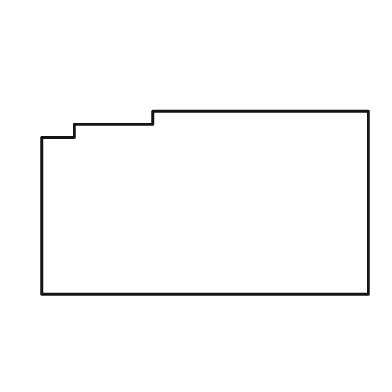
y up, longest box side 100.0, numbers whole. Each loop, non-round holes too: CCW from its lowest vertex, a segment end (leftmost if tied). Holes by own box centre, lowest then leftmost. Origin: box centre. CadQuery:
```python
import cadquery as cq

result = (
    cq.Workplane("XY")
    .moveTo(-50.0, -28.0)
    .lineTo(50.0, -28.0)
    .lineTo(50.0, 28.0)
    .lineTo(-16.0, 28.0)
    .lineTo(-16.0, 24.0)
    .lineTo(-40.0, 24.0)
    .lineTo(-40.0, 20.0)
    .lineTo(-50.0, 20.0)
    .close()
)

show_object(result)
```